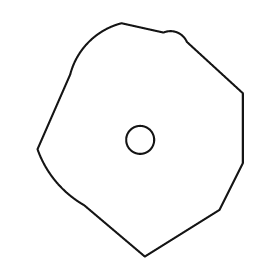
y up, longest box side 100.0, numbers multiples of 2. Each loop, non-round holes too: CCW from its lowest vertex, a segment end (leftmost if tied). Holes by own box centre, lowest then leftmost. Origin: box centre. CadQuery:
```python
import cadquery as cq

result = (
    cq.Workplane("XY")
    .moveTo(2.0, -50.0)
    .lineTo(34.0, -30.0)
    .lineTo(44.0, -10.0)
    .lineTo(44.0, 20.0)
    .lineTo(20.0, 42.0)
    .threePointArc((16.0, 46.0), (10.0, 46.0))
    .lineTo(-8.0, 50.0)
    .threePointArc((-22.0, 42.0), (-30.0, 28.0))
    .lineTo(-44.0, -4.0)
    .threePointArc((-36.0, -18.0), (-24.0, -28.0))
    .close()
    .moveTo(0.0, 0.0)
    .circle(6.0)
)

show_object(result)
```